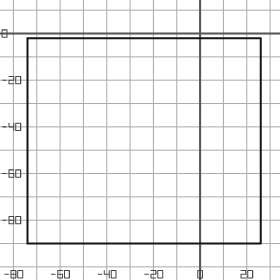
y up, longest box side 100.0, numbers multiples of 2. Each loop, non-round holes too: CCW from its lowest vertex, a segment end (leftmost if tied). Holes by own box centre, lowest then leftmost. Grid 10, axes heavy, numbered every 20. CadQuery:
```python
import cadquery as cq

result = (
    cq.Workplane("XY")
    .moveTo(-74.0, -90.0)
    .lineTo(26.0, -90.0)
    .lineTo(26.0, -2.0)
    .lineTo(-74.0, -2.0)
    .close()
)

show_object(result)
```